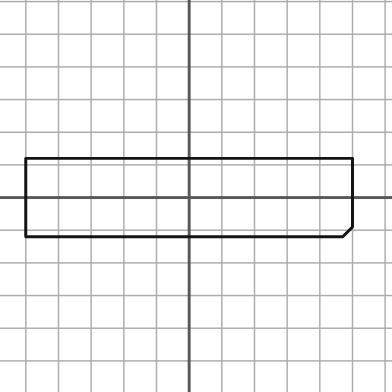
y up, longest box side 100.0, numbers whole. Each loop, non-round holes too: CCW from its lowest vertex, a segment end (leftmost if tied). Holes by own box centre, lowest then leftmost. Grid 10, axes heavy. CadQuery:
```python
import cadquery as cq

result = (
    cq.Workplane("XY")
    .moveTo(-50.0, -12.0)
    .lineTo(47.0, -12.0)
    .lineTo(50.0, -9.0)
    .lineTo(50.0, 12.0)
    .lineTo(-50.0, 12.0)
    .close()
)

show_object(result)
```